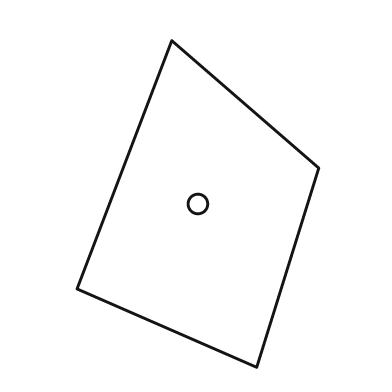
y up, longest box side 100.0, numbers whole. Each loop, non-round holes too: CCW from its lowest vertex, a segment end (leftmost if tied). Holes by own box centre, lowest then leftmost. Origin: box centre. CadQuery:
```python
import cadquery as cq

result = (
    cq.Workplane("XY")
    .moveTo(18.0, -50.0)
    .lineTo(37.0, 11.0)
    .lineTo(-8.0, 50.0)
    .lineTo(-37.0, -26.0)
    .close()
    .moveTo(0.0, 0.0)
    .circle(3.0)
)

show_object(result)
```